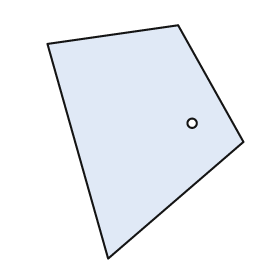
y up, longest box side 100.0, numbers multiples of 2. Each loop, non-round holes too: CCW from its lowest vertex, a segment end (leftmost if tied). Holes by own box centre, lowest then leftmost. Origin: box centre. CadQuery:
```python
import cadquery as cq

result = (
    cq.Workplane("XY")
    .moveTo(-16.0, -50.0)
    .lineTo(42.0, 0.0)
    .lineTo(14.0, 50.0)
    .lineTo(-42.0, 42.0)
    .close()
    .moveTo(20.0, 8.0)
    .circle(2.0)
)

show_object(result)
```